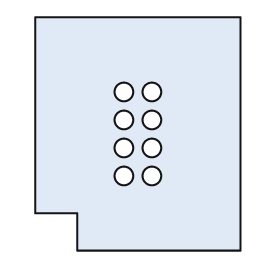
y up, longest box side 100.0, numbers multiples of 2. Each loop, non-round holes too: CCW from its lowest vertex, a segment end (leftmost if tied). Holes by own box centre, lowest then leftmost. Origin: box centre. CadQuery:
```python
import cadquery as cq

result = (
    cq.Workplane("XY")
    .moveTo(-26.0, -50.0)
    .lineTo(44.0, -50.0)
    .lineTo(44.0, 50.0)
    .lineTo(-44.0, 50.0)
    .lineTo(-44.0, -34.0)
    .lineTo(-26.0, -34.0)
    .close()
    .moveTo(-6.0, -18.0)
    .circle(4.0)
    .moveTo(6.0, -18.0)
    .circle(4.0)
    .moveTo(-6.0, -6.0)
    .circle(4.0)
    .moveTo(6.0, -6.0)
    .circle(4.0)
    .moveTo(-6.0, 6.0)
    .circle(4.0)
    .moveTo(6.0, 6.0)
    .circle(4.0)
    .moveTo(-6.0, 18.0)
    .circle(4.0)
    .moveTo(6.0, 18.0)
    .circle(4.0)
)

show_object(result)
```